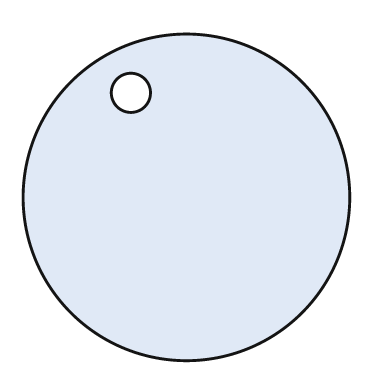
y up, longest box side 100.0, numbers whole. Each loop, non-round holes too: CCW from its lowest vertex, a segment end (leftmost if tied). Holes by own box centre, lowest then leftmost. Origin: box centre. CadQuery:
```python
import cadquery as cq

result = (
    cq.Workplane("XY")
    .moveTo(0.0, 0.0)
    .circle(50.0)
    .moveTo(-17.0, 32.0)
    .circle(6.0)
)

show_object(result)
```